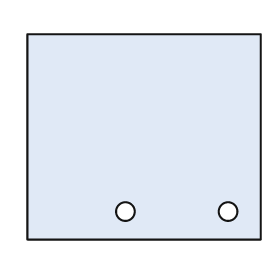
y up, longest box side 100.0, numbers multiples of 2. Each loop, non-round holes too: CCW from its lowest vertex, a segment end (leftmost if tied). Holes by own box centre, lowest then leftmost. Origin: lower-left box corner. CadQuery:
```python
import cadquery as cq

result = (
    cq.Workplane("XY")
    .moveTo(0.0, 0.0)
    .lineTo(100.0, 0.0)
    .lineTo(100.0, 88.0)
    .lineTo(0.0, 88.0)
    .close()
    .moveTo(42.0, 12.0)
    .circle(4.0)
    .moveTo(86.0, 12.0)
    .circle(4.0)
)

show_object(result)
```